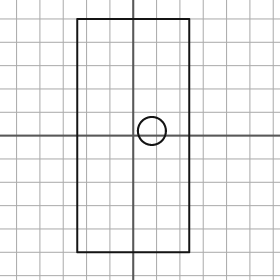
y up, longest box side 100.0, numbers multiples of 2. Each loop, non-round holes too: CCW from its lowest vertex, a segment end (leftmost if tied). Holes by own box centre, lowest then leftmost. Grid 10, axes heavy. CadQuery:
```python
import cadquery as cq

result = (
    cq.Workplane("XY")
    .moveTo(-24.0, -50.0)
    .lineTo(24.0, -50.0)
    .lineTo(24.0, 50.0)
    .lineTo(-24.0, 50.0)
    .close()
    .moveTo(8.0, 2.0)
    .circle(6.0)
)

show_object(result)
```